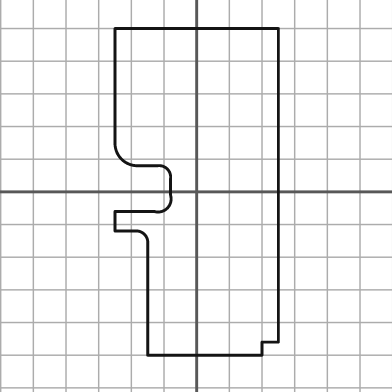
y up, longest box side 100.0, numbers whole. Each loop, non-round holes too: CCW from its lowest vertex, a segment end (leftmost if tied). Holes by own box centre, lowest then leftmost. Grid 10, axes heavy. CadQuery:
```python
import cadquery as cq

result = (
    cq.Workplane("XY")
    .moveTo(-15.0, -50.0)
    .lineTo(20.0, -50.0)
    .lineTo(20.0, -46.0)
    .lineTo(25.0, -46.0)
    .lineTo(25.0, 50.0)
    .lineTo(-25.0, 50.0)
    .lineTo(-25.0, 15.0)
    .threePointArc((-23.0, 10.0), (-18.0, 8.0))
    .lineTo(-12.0, 8.0)
    .threePointArc((-9.0, 7.0), (-8.0, 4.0))
    .lineTo(-8.0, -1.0)
    .threePointArc((-9.0, -5.0), (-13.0, -6.0))
    .lineTo(-25.0, -6.0)
    .lineTo(-25.0, -12.0)
    .lineTo(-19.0, -12.0)
    .threePointArc((-16.0, -13.0), (-15.0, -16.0))
    .close()
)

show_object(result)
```